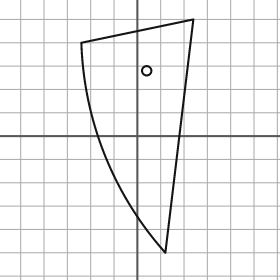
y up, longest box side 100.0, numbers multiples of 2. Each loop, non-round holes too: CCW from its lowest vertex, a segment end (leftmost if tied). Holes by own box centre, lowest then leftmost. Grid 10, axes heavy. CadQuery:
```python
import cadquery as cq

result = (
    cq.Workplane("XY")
    .moveTo(12.0, -50.0)
    .lineTo(24.0, 50.0)
    .lineTo(-24.0, 40.0)
    .threePointArc((-14.0, -8.0), (12.0, -50.0))
    .close()
    .moveTo(4.0, 28.0)
    .circle(2.0)
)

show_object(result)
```